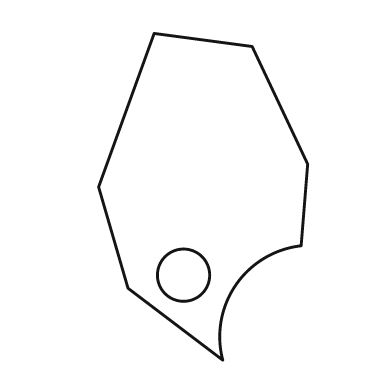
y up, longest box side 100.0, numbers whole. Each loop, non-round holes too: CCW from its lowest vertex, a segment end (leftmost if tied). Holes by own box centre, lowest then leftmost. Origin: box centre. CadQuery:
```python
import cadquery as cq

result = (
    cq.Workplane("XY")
    .moveTo(6.0, -50.0)
    .threePointArc((10.0, -27.0), (30.0, -15.0))
    .lineTo(32.0, 10.0)
    .lineTo(15.0, 46.0)
    .lineTo(-15.0, 50.0)
    .lineTo(-32.0, 3.0)
    .lineTo(-23.0, -28.0)
    .close()
    .moveTo(-6.0, -24.0)
    .circle(8.0)
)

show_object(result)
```